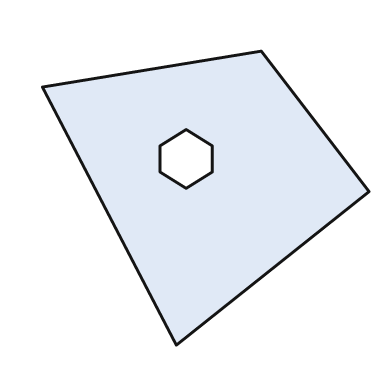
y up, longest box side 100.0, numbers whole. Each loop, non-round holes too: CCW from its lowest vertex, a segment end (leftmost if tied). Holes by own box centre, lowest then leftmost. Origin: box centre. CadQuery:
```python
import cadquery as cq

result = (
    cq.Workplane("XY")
    .moveTo(-9.0, -45.0)
    .lineTo(50.0, 2.0)
    .lineTo(17.0, 45.0)
    .lineTo(-50.0, 34.0)
    .close()
    .moveTo(-6.0, 3.0)
    .lineTo(2.0, 8.0)
    .lineTo(2.0, 16.0)
    .lineTo(-6.0, 21.0)
    .lineTo(-14.0, 16.0)
    .lineTo(-14.0, 8.0)
    .close()
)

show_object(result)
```